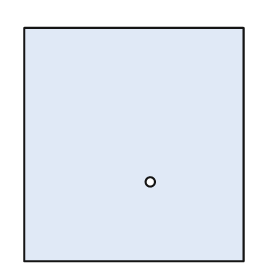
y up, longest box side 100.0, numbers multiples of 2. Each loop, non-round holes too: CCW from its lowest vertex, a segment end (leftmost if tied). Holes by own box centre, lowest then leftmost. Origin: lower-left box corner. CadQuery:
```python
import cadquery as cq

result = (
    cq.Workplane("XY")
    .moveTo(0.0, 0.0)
    .lineTo(94.0, 0.0)
    .lineTo(94.0, 100.0)
    .lineTo(0.0, 100.0)
    .close()
    .moveTo(54.0, 34.0)
    .circle(2.0)
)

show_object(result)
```